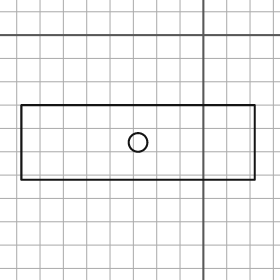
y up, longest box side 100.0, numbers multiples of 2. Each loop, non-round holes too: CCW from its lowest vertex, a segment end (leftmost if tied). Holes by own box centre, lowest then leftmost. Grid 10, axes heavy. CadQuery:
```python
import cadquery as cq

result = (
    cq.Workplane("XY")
    .moveTo(-78.0, -62.0)
    .lineTo(22.0, -62.0)
    .lineTo(22.0, -30.0)
    .lineTo(-78.0, -30.0)
    .close()
    .moveTo(-28.0, -46.0)
    .circle(4.0)
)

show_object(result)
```